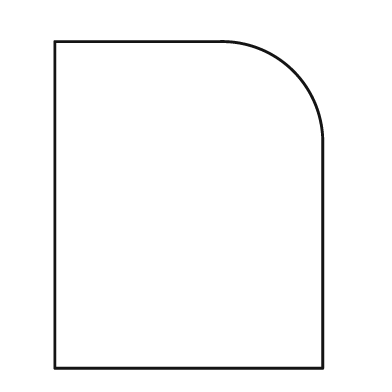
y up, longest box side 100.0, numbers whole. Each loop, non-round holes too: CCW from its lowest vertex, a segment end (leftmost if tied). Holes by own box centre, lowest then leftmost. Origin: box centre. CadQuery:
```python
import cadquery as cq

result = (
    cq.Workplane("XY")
    .moveTo(-41.0, -50.0)
    .lineTo(41.0, -50.0)
    .lineTo(41.0, 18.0)
    .threePointArc((32.0, 41.0), (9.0, 50.0))
    .lineTo(-41.0, 50.0)
    .close()
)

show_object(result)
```